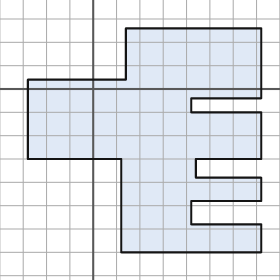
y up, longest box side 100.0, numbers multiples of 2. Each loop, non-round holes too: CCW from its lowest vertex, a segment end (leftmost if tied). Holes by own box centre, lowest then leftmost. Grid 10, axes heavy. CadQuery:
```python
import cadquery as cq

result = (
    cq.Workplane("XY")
    .moveTo(12.0, -70.0)
    .lineTo(72.0, -70.0)
    .lineTo(72.0, -58.0)
    .lineTo(42.0, -58.0)
    .lineTo(42.0, -48.0)
    .lineTo(72.0, -48.0)
    .lineTo(72.0, -38.0)
    .lineTo(44.0, -38.0)
    .lineTo(44.0, -30.0)
    .lineTo(72.0, -30.0)
    .lineTo(72.0, -10.0)
    .lineTo(42.0, -10.0)
    .lineTo(42.0, -4.0)
    .lineTo(72.0, -4.0)
    .lineTo(72.0, 26.0)
    .lineTo(14.0, 26.0)
    .lineTo(14.0, 4.0)
    .lineTo(-28.0, 4.0)
    .lineTo(-28.0, -30.0)
    .lineTo(12.0, -30.0)
    .close()
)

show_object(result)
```